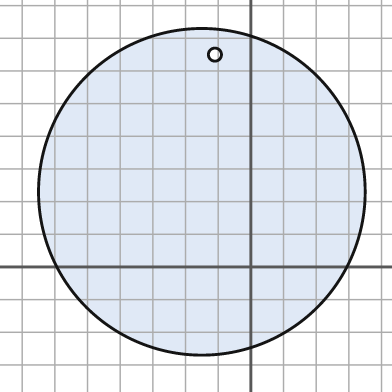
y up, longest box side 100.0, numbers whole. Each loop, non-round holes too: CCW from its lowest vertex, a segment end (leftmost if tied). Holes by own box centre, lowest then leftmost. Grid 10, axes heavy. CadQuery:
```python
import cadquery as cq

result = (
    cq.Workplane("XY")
    .moveTo(-15.0, 23.0)
    .circle(50.0)
    .moveTo(-11.0, 65.0)
    .circle(2.0)
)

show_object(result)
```